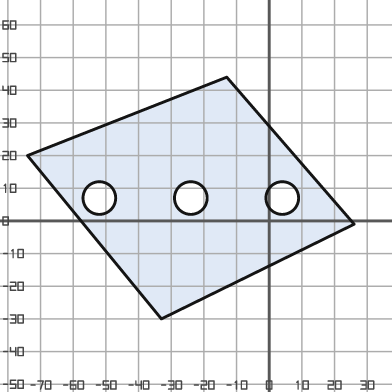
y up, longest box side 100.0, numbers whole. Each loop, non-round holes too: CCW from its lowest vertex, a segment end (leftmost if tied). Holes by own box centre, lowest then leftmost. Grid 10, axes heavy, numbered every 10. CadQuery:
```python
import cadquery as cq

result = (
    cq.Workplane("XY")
    .moveTo(-33.0, -30.0)
    .lineTo(26.0, -1.0)
    .lineTo(-13.0, 44.0)
    .lineTo(-74.0, 20.0)
    .close()
    .moveTo(-52.0, 7.0)
    .circle(5.0)
    .moveTo(-24.0, 7.0)
    .circle(5.0)
    .moveTo(4.0, 7.0)
    .circle(5.0)
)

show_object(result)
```